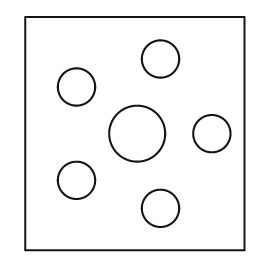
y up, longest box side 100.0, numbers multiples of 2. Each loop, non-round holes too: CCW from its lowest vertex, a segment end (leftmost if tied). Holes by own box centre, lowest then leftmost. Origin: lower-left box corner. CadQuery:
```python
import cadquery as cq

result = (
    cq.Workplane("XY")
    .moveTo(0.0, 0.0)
    .lineTo(94.0, 0.0)
    .lineTo(94.0, 100.0)
    .lineTo(0.0, 100.0)
    .close()
    .moveTo(58.0, 18.0)
    .circle(8.0)
    .moveTo(22.0, 30.0)
    .circle(8.0)
    .moveTo(48.0, 50.0)
    .circle(12.0)
    .moveTo(80.0, 50.0)
    .circle(8.0)
    .moveTo(22.0, 70.0)
    .circle(8.0)
    .moveTo(58.0, 82.0)
    .circle(8.0)
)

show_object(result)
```